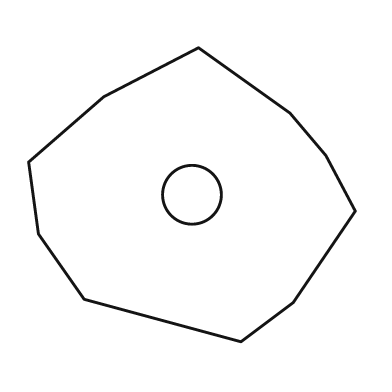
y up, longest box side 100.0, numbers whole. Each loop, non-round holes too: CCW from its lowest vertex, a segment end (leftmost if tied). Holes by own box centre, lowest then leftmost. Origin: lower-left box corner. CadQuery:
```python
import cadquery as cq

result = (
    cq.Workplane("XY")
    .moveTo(65.0, 0.0)
    .lineTo(81.0, 12.0)
    .lineTo(100.0, 40.0)
    .lineTo(91.0, 57.0)
    .lineTo(80.0, 70.0)
    .lineTo(52.0, 90.0)
    .lineTo(23.0, 75.0)
    .lineTo(0.0, 55.0)
    .lineTo(3.0, 33.0)
    .lineTo(17.0, 13.0)
    .close()
    .moveTo(50.0, 45.0)
    .circle(9.0)
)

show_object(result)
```